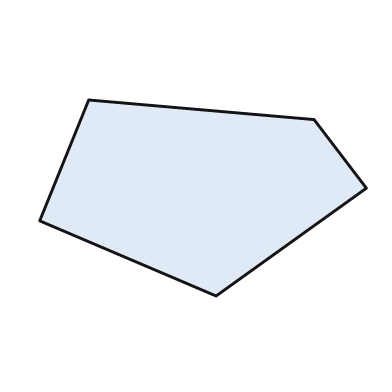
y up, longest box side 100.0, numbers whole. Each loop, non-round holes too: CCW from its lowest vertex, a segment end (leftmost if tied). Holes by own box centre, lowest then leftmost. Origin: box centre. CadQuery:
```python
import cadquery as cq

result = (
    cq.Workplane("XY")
    .moveTo(4.0, -30.0)
    .lineTo(50.0, 3.0)
    .lineTo(34.0, 24.0)
    .lineTo(-35.0, 30.0)
    .lineTo(-50.0, -7.0)
    .close()
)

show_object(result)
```